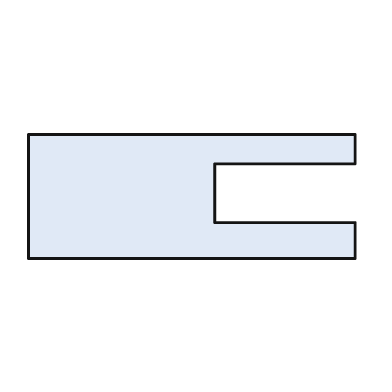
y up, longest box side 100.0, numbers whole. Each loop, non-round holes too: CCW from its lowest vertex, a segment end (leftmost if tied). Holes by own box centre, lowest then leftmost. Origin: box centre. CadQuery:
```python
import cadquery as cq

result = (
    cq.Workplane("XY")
    .moveTo(-50.0, -19.0)
    .lineTo(50.0, -19.0)
    .lineTo(50.0, -8.0)
    .lineTo(7.0, -8.0)
    .lineTo(7.0, 10.0)
    .lineTo(50.0, 10.0)
    .lineTo(50.0, 19.0)
    .lineTo(-50.0, 19.0)
    .close()
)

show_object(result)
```